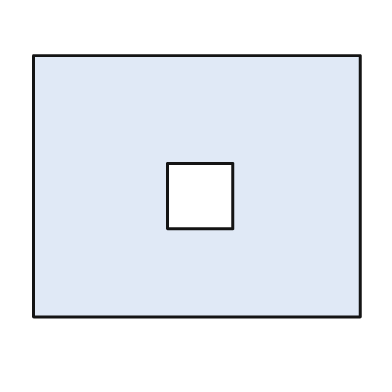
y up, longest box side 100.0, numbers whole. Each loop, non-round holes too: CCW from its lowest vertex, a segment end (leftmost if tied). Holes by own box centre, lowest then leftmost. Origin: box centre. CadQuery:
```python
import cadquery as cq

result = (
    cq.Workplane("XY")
    .moveTo(-50.0, -40.0)
    .lineTo(50.0, -40.0)
    .lineTo(50.0, 40.0)
    .lineTo(-50.0, 40.0)
    .close()
    .moveTo(-9.0, -13.0)
    .lineTo(11.0, -13.0)
    .lineTo(11.0, 7.0)
    .lineTo(-9.0, 7.0)
    .close()
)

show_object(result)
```